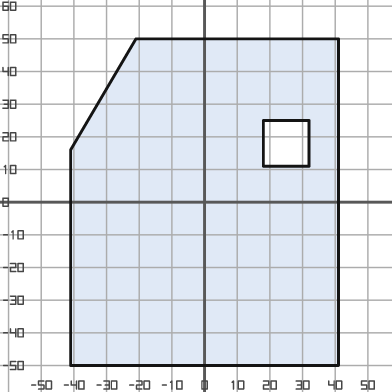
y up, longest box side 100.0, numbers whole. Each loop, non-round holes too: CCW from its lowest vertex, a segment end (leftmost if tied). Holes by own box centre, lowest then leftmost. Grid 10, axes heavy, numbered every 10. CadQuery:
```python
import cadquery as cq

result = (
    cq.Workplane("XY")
    .moveTo(-41.0, -50.0)
    .lineTo(41.0, -50.0)
    .lineTo(41.0, 50.0)
    .lineTo(-21.0, 50.0)
    .lineTo(-41.0, 16.0)
    .close()
    .moveTo(18.0, 11.0)
    .lineTo(32.0, 11.0)
    .lineTo(32.0, 25.0)
    .lineTo(18.0, 25.0)
    .close()
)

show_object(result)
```